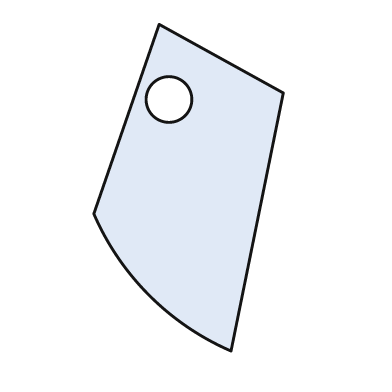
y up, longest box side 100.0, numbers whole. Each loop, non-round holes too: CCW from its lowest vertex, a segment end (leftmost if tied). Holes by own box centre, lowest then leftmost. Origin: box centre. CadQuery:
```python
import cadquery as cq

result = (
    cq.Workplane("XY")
    .moveTo(13.0, -50.0)
    .lineTo(29.0, 29.0)
    .lineTo(-9.0, 50.0)
    .lineTo(-29.0, -8.0)
    .threePointArc((-12.0, -33.0), (13.0, -50.0))
    .close()
    .moveTo(-6.0, 27.0)
    .circle(7.0)
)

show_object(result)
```